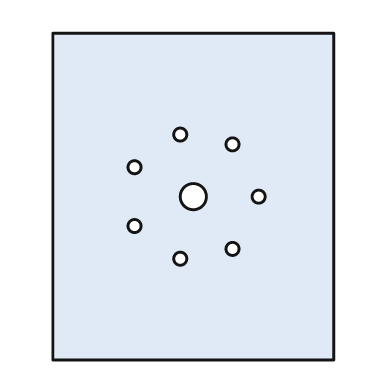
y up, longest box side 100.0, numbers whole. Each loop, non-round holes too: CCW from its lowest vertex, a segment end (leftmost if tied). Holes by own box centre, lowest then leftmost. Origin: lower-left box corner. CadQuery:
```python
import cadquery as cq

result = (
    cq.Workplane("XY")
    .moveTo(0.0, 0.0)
    .lineTo(86.0, 0.0)
    .lineTo(86.0, 100.0)
    .lineTo(0.0, 100.0)
    .close()
    .moveTo(39.0, 31.0)
    .circle(2.0)
    .moveTo(55.0, 34.0)
    .circle(2.0)
    .moveTo(25.0, 41.0)
    .circle(2.0)
    .moveTo(43.0, 50.0)
    .circle(4.0)
    .moveTo(63.0, 50.0)
    .circle(2.0)
    .moveTo(25.0, 59.0)
    .circle(2.0)
    .moveTo(55.0, 66.0)
    .circle(2.0)
    .moveTo(39.0, 69.0)
    .circle(2.0)
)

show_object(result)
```